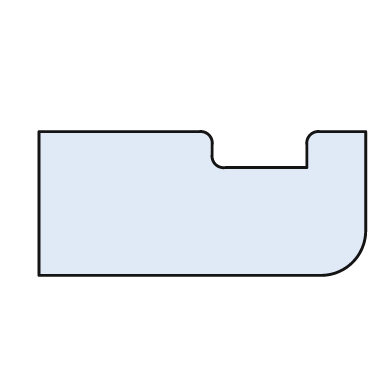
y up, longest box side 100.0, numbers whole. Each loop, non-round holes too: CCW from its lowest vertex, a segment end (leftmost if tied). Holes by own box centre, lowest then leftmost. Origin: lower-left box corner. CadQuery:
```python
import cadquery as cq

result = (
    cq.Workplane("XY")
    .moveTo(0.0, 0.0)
    .lineTo(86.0, 0.0)
    .threePointArc((96.0, 4.0), (100.0, 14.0))
    .lineTo(100.0, 44.0)
    .lineTo(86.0, 44.0)
    .threePointArc((83.0, 43.0), (82.0, 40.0))
    .lineTo(82.0, 33.0)
    .lineTo(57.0, 33.0)
    .threePointArc((54.0, 34.0), (53.0, 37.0))
    .lineTo(53.0, 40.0)
    .threePointArc((52.0, 43.0), (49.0, 44.0))
    .lineTo(0.0, 44.0)
    .close()
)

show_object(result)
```